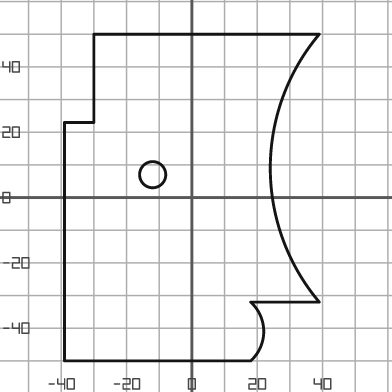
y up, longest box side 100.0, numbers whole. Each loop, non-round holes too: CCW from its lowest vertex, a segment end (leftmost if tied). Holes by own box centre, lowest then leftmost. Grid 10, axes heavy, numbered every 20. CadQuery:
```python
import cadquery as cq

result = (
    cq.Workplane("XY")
    .moveTo(-39.0, -50.0)
    .lineTo(18.0, -50.0)
    .threePointArc((22.0, -41.0), (18.0, -32.0))
    .lineTo(39.0, -32.0)
    .threePointArc((24.0, 9.0), (39.0, 50.0))
    .lineTo(-30.0, 50.0)
    .lineTo(-30.0, 23.0)
    .lineTo(-39.0, 23.0)
    .close()
    .moveTo(-12.0, 7.0)
    .circle(4.0)
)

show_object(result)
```